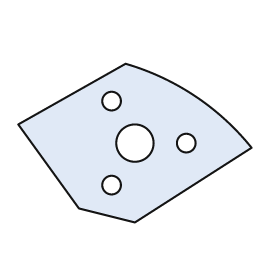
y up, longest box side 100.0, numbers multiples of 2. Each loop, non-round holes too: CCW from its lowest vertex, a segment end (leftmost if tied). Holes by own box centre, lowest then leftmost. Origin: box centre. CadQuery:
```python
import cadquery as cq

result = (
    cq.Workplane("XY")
    .moveTo(0.0, -34.0)
    .lineTo(50.0, -2.0)
    .threePointArc((26.0, 20.0), (-4.0, 34.0))
    .lineTo(-50.0, 8.0)
    .lineTo(-24.0, -28.0)
    .close()
    .moveTo(-10.0, -18.0)
    .circle(4.0)
    .moveTo(0.0, 0.0)
    .circle(8.0)
    .moveTo(22.0, 0.0)
    .circle(4.0)
    .moveTo(-10.0, 18.0)
    .circle(4.0)
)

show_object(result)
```